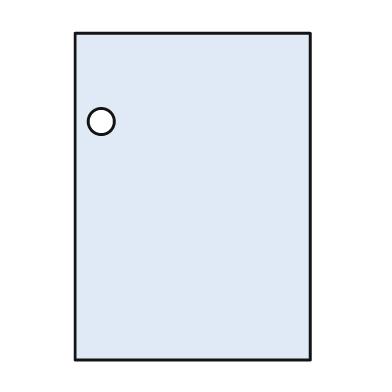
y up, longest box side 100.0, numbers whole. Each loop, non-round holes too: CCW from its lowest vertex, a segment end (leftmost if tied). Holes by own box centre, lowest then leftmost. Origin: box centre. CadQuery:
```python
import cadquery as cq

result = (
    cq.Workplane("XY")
    .moveTo(-36.0, -50.0)
    .lineTo(36.0, -50.0)
    .lineTo(36.0, 50.0)
    .lineTo(-36.0, 50.0)
    .close()
    .moveTo(-28.0, 23.0)
    .circle(4.0)
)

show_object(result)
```